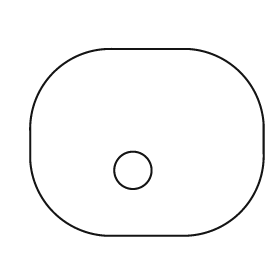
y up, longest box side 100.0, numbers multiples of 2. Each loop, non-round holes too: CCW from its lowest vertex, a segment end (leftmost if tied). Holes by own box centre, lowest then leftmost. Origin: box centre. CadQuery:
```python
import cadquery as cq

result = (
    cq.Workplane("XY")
    .moveTo(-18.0, -40.0)
    .lineTo(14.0, -40.0)
    .threePointArc((40.0, -30.0), (50.0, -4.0))
    .lineTo(50.0, 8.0)
    .threePointArc((40.0, 30.0), (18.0, 40.0))
    .lineTo(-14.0, 40.0)
    .threePointArc((-40.0, 30.0), (-50.0, 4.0))
    .lineTo(-50.0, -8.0)
    .threePointArc((-40.0, -30.0), (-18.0, -40.0))
    .close()
    .moveTo(-6.0, -12.0)
    .circle(8.0)
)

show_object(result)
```